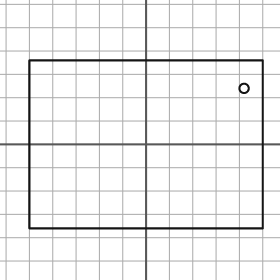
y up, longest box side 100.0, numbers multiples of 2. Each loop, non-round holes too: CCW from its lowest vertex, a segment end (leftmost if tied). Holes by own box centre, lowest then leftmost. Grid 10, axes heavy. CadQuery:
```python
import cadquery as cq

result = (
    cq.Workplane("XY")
    .moveTo(-50.0, -36.0)
    .lineTo(50.0, -36.0)
    .lineTo(50.0, 36.0)
    .lineTo(-50.0, 36.0)
    .close()
    .moveTo(42.0, 24.0)
    .circle(2.0)
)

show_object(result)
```